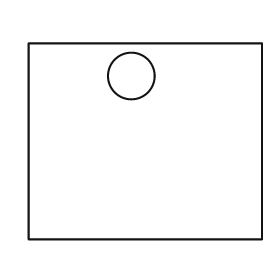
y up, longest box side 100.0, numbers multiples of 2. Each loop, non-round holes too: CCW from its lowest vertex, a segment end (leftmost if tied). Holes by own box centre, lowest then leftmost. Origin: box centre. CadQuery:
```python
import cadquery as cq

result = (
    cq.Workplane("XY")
    .moveTo(-50.0, -42.0)
    .lineTo(50.0, -42.0)
    .lineTo(50.0, 42.0)
    .lineTo(-50.0, 42.0)
    .close()
    .moveTo(-6.0, 28.0)
    .circle(10.0)
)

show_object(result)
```